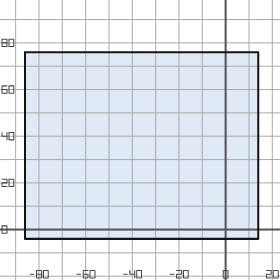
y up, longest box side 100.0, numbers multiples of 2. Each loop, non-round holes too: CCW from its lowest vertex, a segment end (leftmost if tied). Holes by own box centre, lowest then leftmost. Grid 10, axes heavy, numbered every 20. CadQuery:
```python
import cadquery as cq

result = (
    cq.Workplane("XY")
    .moveTo(-86.0, -4.0)
    .lineTo(14.0, -4.0)
    .lineTo(14.0, 76.0)
    .lineTo(-86.0, 76.0)
    .close()
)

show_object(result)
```